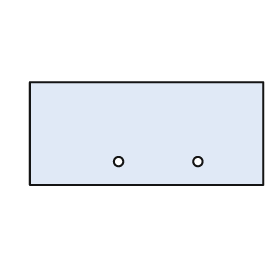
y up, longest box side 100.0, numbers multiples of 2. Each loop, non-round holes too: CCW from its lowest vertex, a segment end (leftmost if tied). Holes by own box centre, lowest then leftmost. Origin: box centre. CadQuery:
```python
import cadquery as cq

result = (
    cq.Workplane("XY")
    .moveTo(-50.0, -22.0)
    .lineTo(50.0, -22.0)
    .lineTo(50.0, 22.0)
    .lineTo(-50.0, 22.0)
    .close()
    .moveTo(-12.0, -12.0)
    .circle(2.0)
    .moveTo(22.0, -12.0)
    .circle(2.0)
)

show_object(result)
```